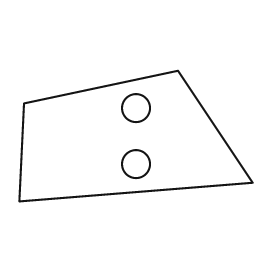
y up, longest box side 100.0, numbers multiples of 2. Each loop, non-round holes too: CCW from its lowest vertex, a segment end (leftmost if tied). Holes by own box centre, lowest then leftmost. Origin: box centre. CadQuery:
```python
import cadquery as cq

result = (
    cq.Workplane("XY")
    .moveTo(-50.0, -28.0)
    .lineTo(50.0, -20.0)
    .lineTo(18.0, 28.0)
    .lineTo(-48.0, 14.0)
    .close()
    .moveTo(0.0, -12.0)
    .circle(6.0)
    .moveTo(0.0, 12.0)
    .circle(6.0)
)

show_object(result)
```